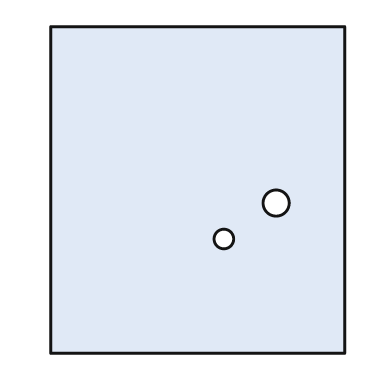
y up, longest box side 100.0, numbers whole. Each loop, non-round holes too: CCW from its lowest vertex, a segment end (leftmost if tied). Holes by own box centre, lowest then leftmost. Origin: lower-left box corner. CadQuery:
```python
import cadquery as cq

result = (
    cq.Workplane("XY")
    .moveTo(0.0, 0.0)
    .lineTo(90.0, 0.0)
    .lineTo(90.0, 100.0)
    .lineTo(0.0, 100.0)
    .close()
    .moveTo(53.0, 35.0)
    .circle(3.0)
    .moveTo(69.0, 46.0)
    .circle(4.0)
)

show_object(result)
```